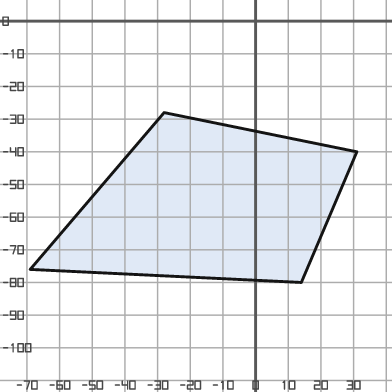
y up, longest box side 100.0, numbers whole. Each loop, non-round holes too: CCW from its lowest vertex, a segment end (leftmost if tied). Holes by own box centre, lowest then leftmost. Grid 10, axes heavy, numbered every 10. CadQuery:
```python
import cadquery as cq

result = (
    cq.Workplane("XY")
    .moveTo(14.0, -80.0)
    .lineTo(31.0, -40.0)
    .lineTo(-28.0, -28.0)
    .lineTo(-69.0, -76.0)
    .close()
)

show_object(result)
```